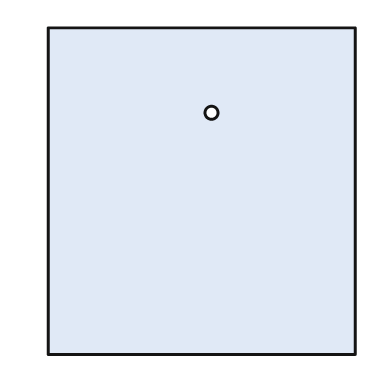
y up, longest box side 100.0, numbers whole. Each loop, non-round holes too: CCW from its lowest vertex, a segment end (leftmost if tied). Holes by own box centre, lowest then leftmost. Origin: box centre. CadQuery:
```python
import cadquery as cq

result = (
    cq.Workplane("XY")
    .moveTo(-47.0, -50.0)
    .lineTo(47.0, -50.0)
    .lineTo(47.0, 50.0)
    .lineTo(-47.0, 50.0)
    .close()
    .moveTo(3.0, 24.0)
    .circle(2.0)
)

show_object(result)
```